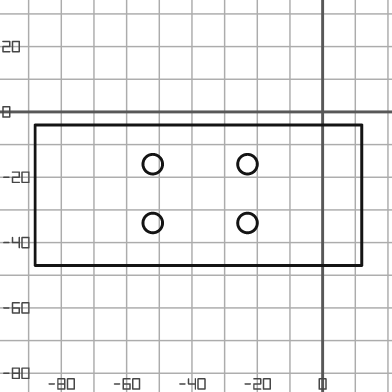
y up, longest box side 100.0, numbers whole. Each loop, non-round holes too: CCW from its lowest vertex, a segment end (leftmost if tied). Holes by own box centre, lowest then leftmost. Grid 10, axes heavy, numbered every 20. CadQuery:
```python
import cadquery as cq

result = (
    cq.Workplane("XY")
    .moveTo(-88.0, -47.0)
    .lineTo(12.0, -47.0)
    .lineTo(12.0, -4.0)
    .lineTo(-88.0, -4.0)
    .close()
    .moveTo(-52.0, -34.0)
    .circle(3.0)
    .moveTo(-23.0, -34.0)
    .circle(3.0)
    .moveTo(-52.0, -16.0)
    .circle(3.0)
    .moveTo(-23.0, -16.0)
    .circle(3.0)
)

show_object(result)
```